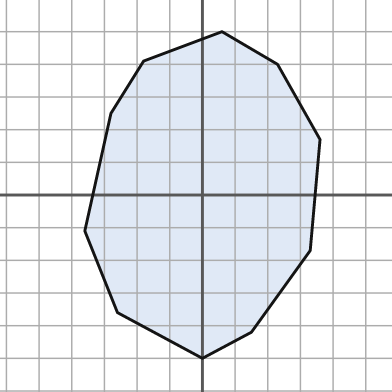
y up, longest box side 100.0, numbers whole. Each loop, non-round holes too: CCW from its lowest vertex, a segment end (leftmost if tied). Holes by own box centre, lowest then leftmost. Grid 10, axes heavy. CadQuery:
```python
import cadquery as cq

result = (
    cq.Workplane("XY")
    .moveTo(0.0, -50.0)
    .lineTo(15.0, -42.0)
    .lineTo(33.0, -17.0)
    .lineTo(36.0, 17.0)
    .lineTo(23.0, 40.0)
    .lineTo(6.0, 50.0)
    .lineTo(-18.0, 41.0)
    .lineTo(-28.0, 25.0)
    .lineTo(-36.0, -11.0)
    .lineTo(-26.0, -36.0)
    .close()
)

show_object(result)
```